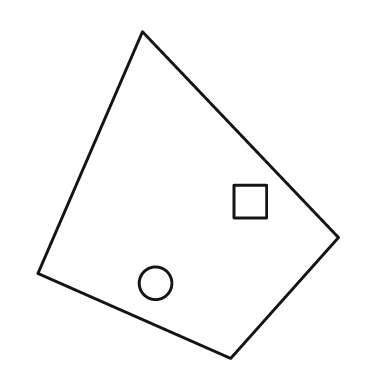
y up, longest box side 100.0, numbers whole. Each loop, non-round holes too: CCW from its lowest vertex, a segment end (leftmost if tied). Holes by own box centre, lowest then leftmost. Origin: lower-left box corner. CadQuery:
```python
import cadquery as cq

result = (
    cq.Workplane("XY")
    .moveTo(59.0, 0.0)
    .lineTo(92.0, 37.0)
    .lineTo(32.0, 100.0)
    .lineTo(0.0, 26.0)
    .close()
    .moveTo(36.0, 23.0)
    .circle(5.0)
    .moveTo(60.0, 43.0)
    .lineTo(70.0, 43.0)
    .lineTo(70.0, 53.0)
    .lineTo(60.0, 53.0)
    .close()
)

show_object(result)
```